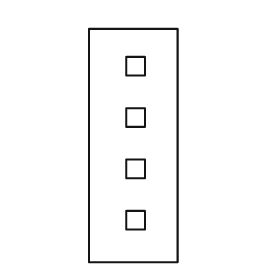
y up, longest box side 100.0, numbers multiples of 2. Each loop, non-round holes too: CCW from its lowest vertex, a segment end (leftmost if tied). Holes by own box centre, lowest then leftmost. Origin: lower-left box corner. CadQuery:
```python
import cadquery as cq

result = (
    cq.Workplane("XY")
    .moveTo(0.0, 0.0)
    .lineTo(38.0, 0.0)
    .lineTo(38.0, 100.0)
    .lineTo(0.0, 100.0)
    .close()
    .moveTo(16.0, 14.0)
    .lineTo(24.0, 14.0)
    .lineTo(24.0, 22.0)
    .lineTo(16.0, 22.0)
    .close()
    .moveTo(16.0, 36.0)
    .lineTo(24.0, 36.0)
    .lineTo(24.0, 44.0)
    .lineTo(16.0, 44.0)
    .close()
    .moveTo(16.0, 58.0)
    .lineTo(24.0, 58.0)
    .lineTo(24.0, 66.0)
    .lineTo(16.0, 66.0)
    .close()
    .moveTo(16.0, 80.0)
    .lineTo(24.0, 80.0)
    .lineTo(24.0, 88.0)
    .lineTo(16.0, 88.0)
    .close()
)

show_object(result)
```